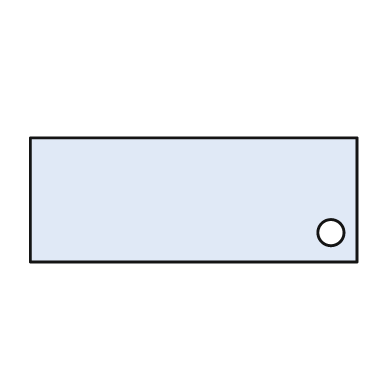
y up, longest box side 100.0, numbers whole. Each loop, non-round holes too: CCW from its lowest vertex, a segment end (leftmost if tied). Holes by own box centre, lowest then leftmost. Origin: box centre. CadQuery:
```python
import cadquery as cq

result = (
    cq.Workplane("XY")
    .moveTo(-50.0, -19.0)
    .lineTo(50.0, -19.0)
    .lineTo(50.0, 19.0)
    .lineTo(-50.0, 19.0)
    .close()
    .moveTo(42.0, -10.0)
    .circle(4.0)
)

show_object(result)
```